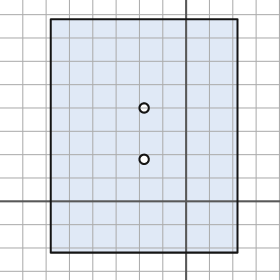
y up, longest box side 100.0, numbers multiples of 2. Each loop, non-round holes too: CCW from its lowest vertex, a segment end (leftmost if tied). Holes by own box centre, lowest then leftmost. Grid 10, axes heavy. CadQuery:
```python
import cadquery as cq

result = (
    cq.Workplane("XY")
    .moveTo(-58.0, -22.0)
    .lineTo(22.0, -22.0)
    .lineTo(22.0, 78.0)
    .lineTo(-58.0, 78.0)
    .close()
    .moveTo(-18.0, 18.0)
    .circle(2.0)
    .moveTo(-18.0, 40.0)
    .circle(2.0)
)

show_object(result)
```